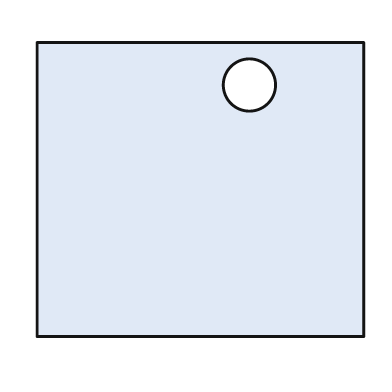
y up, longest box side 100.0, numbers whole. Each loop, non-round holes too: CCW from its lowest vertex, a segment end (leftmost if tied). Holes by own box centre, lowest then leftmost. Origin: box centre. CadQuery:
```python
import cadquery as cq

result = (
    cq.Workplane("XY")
    .moveTo(-50.0, -45.0)
    .lineTo(50.0, -45.0)
    .lineTo(50.0, 45.0)
    .lineTo(-50.0, 45.0)
    .close()
    .moveTo(15.0, 32.0)
    .circle(8.0)
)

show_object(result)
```